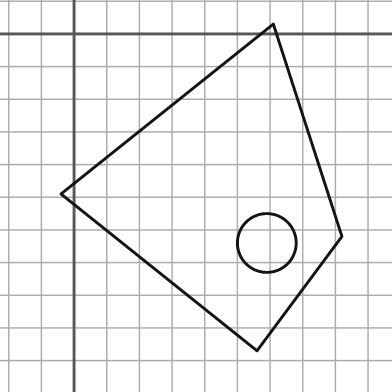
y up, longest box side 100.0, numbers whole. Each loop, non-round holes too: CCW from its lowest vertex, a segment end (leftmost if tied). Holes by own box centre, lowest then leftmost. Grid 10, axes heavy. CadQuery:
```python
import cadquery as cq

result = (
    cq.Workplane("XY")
    .moveTo(56.0, -97.0)
    .lineTo(82.0, -62.0)
    .lineTo(61.0, 3.0)
    .lineTo(-4.0, -49.0)
    .close()
    .moveTo(59.0, -64.0)
    .circle(9.0)
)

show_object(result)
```